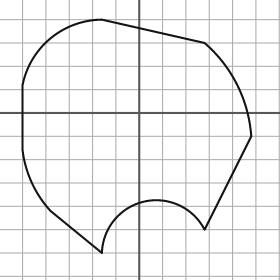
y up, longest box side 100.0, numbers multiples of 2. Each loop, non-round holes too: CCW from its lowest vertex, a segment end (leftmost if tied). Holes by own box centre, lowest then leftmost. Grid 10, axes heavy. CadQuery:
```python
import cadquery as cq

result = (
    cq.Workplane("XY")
    .moveTo(-16.0, -60.0)
    .threePointArc((2.0, -38.0), (28.0, -50.0))
    .lineTo(48.0, -10.0)
    .threePointArc((42.0, 12.0), (28.0, 30.0))
    .lineTo(-16.0, 40.0)
    .threePointArc((-38.0, 32.0), (-50.0, 12.0))
    .lineTo(-50.0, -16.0)
    .threePointArc((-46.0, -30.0), (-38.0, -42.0))
    .close()
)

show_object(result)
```